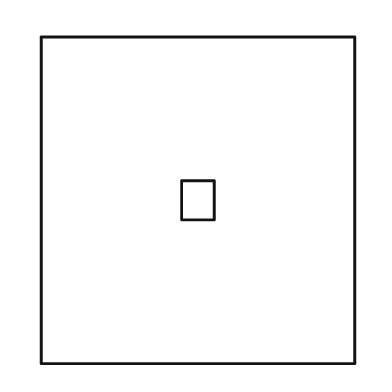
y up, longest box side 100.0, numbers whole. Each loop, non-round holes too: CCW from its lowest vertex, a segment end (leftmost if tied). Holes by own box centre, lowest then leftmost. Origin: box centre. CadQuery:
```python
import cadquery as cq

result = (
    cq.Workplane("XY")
    .moveTo(-48.0, -50.0)
    .lineTo(48.0, -50.0)
    .lineTo(48.0, 50.0)
    .lineTo(-48.0, 50.0)
    .close()
    .moveTo(-5.0, -6.0)
    .lineTo(5.0, -6.0)
    .lineTo(5.0, 6.0)
    .lineTo(-5.0, 6.0)
    .close()
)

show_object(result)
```